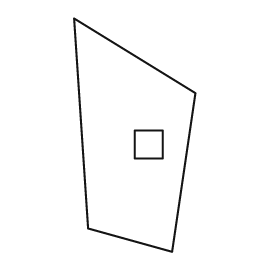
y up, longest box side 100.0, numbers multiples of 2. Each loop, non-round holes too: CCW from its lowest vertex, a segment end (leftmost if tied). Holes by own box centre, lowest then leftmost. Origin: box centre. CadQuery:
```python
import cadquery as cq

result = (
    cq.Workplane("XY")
    .moveTo(16.0, -50.0)
    .lineTo(26.0, 18.0)
    .lineTo(-26.0, 50.0)
    .lineTo(-20.0, -40.0)
    .close()
    .moveTo(0.0, -10.0)
    .lineTo(12.0, -10.0)
    .lineTo(12.0, 2.0)
    .lineTo(0.0, 2.0)
    .close()
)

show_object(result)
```